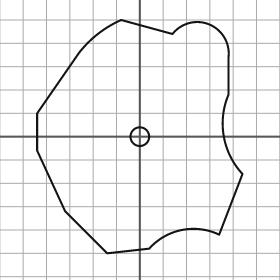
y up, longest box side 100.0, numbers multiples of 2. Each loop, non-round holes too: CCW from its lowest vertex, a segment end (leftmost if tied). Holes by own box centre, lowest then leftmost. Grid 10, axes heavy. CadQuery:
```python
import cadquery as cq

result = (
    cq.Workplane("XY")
    .moveTo(-14.0, -50.0)
    .lineTo(4.0, -48.0)
    .threePointArc((18.0, -40.0), (34.0, -42.0))
    .lineTo(44.0, -16.0)
    .threePointArc((36.0, 0.0), (38.0, 18.0))
    .lineTo(38.0, 34.0)
    .threePointArc((30.0, 48.0), (14.0, 44.0))
    .lineTo(-8.0, 50.0)
    .threePointArc((-18.0, 44.0), (-26.0, 36.0))
    .lineTo(-44.0, 10.0)
    .lineTo(-44.0, -6.0)
    .lineTo(-32.0, -32.0)
    .close()
    .moveTo(0.0, 0.0)
    .circle(4.0)
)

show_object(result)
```